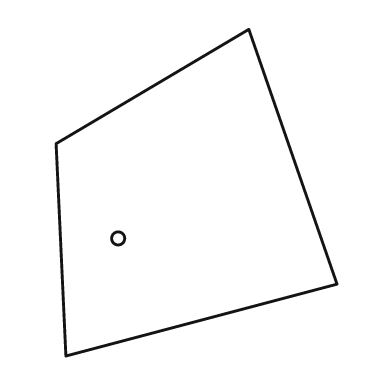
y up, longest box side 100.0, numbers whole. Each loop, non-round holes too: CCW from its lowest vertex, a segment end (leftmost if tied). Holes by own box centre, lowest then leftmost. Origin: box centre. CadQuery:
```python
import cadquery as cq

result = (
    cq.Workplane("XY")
    .moveTo(-40.0, -50.0)
    .lineTo(43.0, -28.0)
    .lineTo(16.0, 50.0)
    .lineTo(-43.0, 15.0)
    .close()
    .moveTo(-24.0, -14.0)
    .circle(2.0)
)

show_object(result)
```